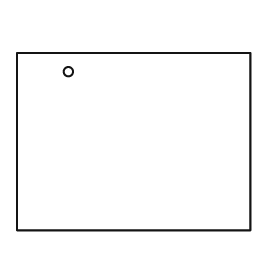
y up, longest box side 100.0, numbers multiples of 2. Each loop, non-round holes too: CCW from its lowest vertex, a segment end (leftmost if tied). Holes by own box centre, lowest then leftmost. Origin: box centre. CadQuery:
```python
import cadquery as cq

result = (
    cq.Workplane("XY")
    .moveTo(-50.0, -38.0)
    .lineTo(50.0, -38.0)
    .lineTo(50.0, 38.0)
    .lineTo(-50.0, 38.0)
    .close()
    .moveTo(-28.0, 30.0)
    .circle(2.0)
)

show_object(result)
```